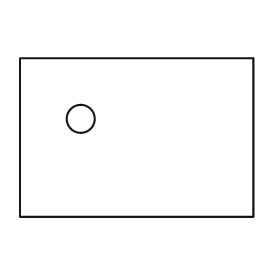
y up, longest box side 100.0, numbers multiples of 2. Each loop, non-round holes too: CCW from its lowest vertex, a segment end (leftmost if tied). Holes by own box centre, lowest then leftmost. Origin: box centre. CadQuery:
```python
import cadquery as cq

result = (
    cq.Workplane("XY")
    .moveTo(-50.0, -34.0)
    .lineTo(50.0, -34.0)
    .lineTo(50.0, 34.0)
    .lineTo(-50.0, 34.0)
    .close()
    .moveTo(-24.0, 8.0)
    .circle(6.0)
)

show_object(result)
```